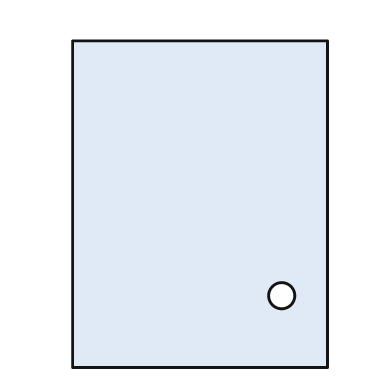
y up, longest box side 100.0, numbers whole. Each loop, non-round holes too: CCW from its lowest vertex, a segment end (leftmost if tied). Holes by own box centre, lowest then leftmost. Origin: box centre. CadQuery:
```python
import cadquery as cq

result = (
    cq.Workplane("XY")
    .moveTo(-39.0, -50.0)
    .lineTo(39.0, -50.0)
    .lineTo(39.0, 50.0)
    .lineTo(-39.0, 50.0)
    .close()
    .moveTo(25.0, -28.0)
    .circle(4.0)
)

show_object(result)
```